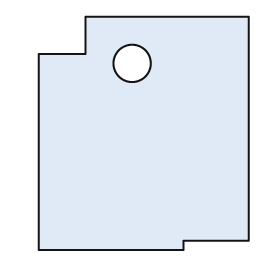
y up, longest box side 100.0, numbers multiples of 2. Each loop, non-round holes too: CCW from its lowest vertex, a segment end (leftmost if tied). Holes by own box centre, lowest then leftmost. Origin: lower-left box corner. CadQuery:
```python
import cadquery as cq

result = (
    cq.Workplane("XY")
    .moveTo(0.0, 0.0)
    .lineTo(62.0, 0.0)
    .lineTo(62.0, 4.0)
    .lineTo(90.0, 4.0)
    .lineTo(90.0, 100.0)
    .lineTo(20.0, 100.0)
    .lineTo(20.0, 84.0)
    .lineTo(0.0, 84.0)
    .close()
    .moveTo(40.0, 80.0)
    .circle(8.0)
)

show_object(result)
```